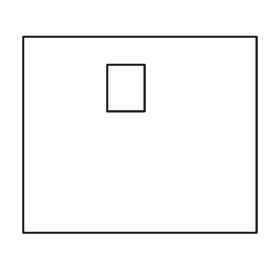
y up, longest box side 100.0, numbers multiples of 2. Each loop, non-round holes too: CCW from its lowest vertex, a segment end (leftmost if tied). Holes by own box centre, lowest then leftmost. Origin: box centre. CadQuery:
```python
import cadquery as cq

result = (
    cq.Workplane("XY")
    .moveTo(-50.0, -42.0)
    .lineTo(50.0, -42.0)
    .lineTo(50.0, 42.0)
    .lineTo(-50.0, 42.0)
    .close()
    .moveTo(-14.0, 10.0)
    .lineTo(2.0, 10.0)
    .lineTo(2.0, 30.0)
    .lineTo(-14.0, 30.0)
    .close()
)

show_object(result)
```